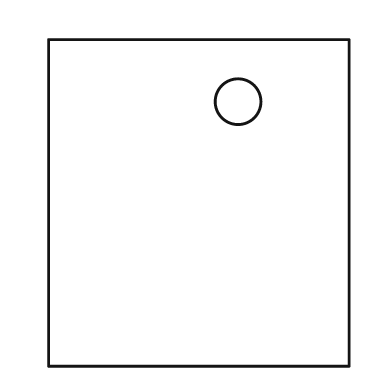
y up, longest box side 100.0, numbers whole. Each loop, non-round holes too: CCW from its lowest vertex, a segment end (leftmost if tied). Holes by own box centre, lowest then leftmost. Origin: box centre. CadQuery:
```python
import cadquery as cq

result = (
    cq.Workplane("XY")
    .moveTo(-46.0, -50.0)
    .lineTo(46.0, -50.0)
    .lineTo(46.0, 50.0)
    .lineTo(-46.0, 50.0)
    .close()
    .moveTo(12.0, 31.0)
    .circle(7.0)
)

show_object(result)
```